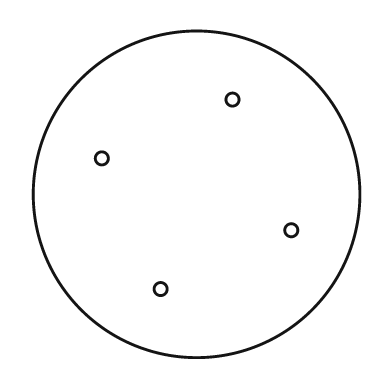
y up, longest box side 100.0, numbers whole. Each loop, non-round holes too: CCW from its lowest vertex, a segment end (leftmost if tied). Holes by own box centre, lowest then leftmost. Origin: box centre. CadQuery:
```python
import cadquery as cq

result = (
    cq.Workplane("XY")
    .moveTo(0.0, 0.0)
    .circle(50.0)
    .moveTo(-11.0, -29.0)
    .circle(2.0)
    .moveTo(29.0, -11.0)
    .circle(2.0)
    .moveTo(-29.0, 11.0)
    .circle(2.0)
    .moveTo(11.0, 29.0)
    .circle(2.0)
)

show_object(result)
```